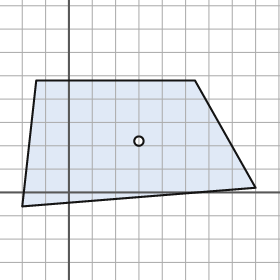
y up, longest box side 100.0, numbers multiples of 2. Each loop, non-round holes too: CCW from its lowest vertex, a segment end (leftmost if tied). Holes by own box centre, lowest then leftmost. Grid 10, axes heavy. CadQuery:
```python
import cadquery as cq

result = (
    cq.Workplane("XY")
    .moveTo(-20.0, -6.0)
    .lineTo(80.0, 2.0)
    .lineTo(54.0, 48.0)
    .lineTo(-14.0, 48.0)
    .close()
    .moveTo(30.0, 22.0)
    .circle(2.0)
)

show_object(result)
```